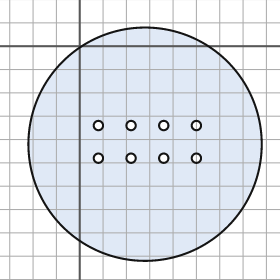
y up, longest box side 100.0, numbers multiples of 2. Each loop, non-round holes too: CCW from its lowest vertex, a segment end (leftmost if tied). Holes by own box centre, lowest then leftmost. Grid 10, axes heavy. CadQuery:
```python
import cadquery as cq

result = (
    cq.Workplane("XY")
    .moveTo(28.0, -42.0)
    .circle(50.0)
    .moveTo(8.0, -48.0)
    .circle(2.0)
    .moveTo(22.0, -48.0)
    .circle(2.0)
    .moveTo(36.0, -48.0)
    .circle(2.0)
    .moveTo(50.0, -48.0)
    .circle(2.0)
    .moveTo(8.0, -34.0)
    .circle(2.0)
    .moveTo(22.0, -34.0)
    .circle(2.0)
    .moveTo(36.0, -34.0)
    .circle(2.0)
    .moveTo(50.0, -34.0)
    .circle(2.0)
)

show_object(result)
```